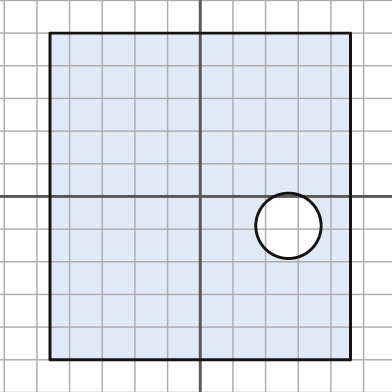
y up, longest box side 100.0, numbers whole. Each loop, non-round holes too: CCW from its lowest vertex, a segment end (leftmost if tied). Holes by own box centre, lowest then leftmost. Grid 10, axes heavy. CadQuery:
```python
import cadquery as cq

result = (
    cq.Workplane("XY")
    .moveTo(-46.0, -50.0)
    .lineTo(46.0, -50.0)
    .lineTo(46.0, 50.0)
    .lineTo(-46.0, 50.0)
    .close()
    .moveTo(27.0, -9.0)
    .circle(10.0)
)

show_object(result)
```